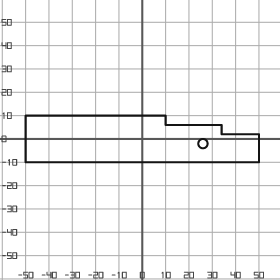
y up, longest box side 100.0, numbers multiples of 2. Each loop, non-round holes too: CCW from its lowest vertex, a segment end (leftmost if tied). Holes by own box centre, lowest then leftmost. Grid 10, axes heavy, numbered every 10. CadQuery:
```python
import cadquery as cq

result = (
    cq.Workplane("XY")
    .moveTo(-50.0, -10.0)
    .lineTo(50.0, -10.0)
    .lineTo(50.0, 2.0)
    .lineTo(34.0, 2.0)
    .lineTo(34.0, 6.0)
    .lineTo(10.0, 6.0)
    .lineTo(10.0, 10.0)
    .lineTo(-50.0, 10.0)
    .close()
    .moveTo(26.0, -2.0)
    .circle(2.0)
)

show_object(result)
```